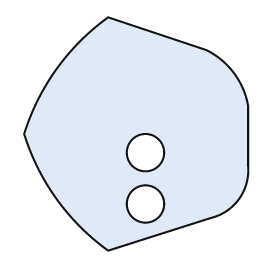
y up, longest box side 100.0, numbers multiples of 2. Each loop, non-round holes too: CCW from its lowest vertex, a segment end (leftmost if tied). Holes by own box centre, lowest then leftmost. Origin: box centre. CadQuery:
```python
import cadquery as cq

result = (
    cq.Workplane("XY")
    .moveTo(-12.0, -50.0)
    .lineTo(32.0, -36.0)
    .threePointArc((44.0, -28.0), (48.0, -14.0))
    .lineTo(48.0, 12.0)
    .threePointArc((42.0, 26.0), (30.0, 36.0))
    .lineTo(-12.0, 50.0)
    .threePointArc((-34.0, 28.0), (-48.0, 0.0))
    .threePointArc((-34.0, -28.0), (-12.0, -50.0))
    .close()
    .moveTo(4.0, -30.0)
    .circle(8.0)
    .moveTo(4.0, -8.0)
    .circle(8.0)
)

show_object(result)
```